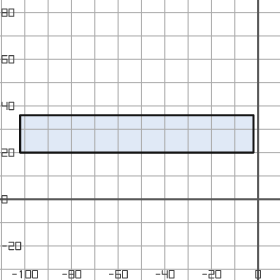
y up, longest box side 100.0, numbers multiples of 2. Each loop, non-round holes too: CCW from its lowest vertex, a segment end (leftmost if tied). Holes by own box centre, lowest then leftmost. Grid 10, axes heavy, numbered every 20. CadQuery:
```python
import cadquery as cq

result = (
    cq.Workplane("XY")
    .moveTo(-102.0, 20.0)
    .lineTo(-2.0, 20.0)
    .lineTo(-2.0, 36.0)
    .lineTo(-102.0, 36.0)
    .close()
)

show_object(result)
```